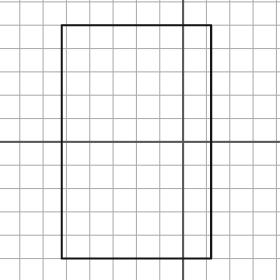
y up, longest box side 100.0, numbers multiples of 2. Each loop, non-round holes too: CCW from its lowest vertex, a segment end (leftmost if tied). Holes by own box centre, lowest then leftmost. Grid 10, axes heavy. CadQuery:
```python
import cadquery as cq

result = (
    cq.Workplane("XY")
    .moveTo(-52.0, -50.0)
    .lineTo(12.0, -50.0)
    .lineTo(12.0, 50.0)
    .lineTo(-52.0, 50.0)
    .close()
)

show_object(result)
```